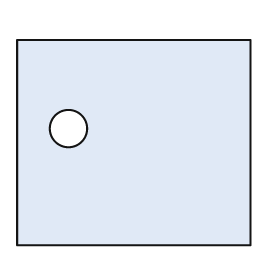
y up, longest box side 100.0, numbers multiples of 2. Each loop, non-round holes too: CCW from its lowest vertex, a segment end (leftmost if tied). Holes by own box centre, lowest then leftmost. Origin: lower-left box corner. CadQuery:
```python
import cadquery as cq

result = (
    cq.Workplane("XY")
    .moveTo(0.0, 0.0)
    .lineTo(100.0, 0.0)
    .lineTo(100.0, 88.0)
    .lineTo(0.0, 88.0)
    .close()
    .moveTo(22.0, 50.0)
    .circle(8.0)
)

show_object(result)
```